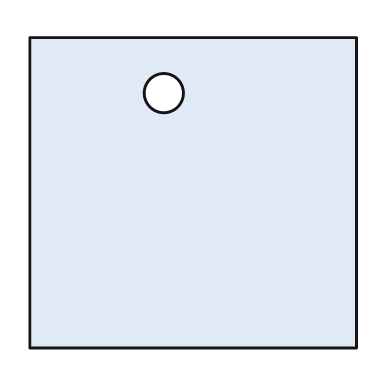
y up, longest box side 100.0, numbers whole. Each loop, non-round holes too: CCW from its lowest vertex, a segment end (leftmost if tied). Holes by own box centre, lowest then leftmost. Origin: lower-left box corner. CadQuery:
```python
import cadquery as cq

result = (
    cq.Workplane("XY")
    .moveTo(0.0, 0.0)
    .lineTo(100.0, 0.0)
    .lineTo(100.0, 95.0)
    .lineTo(0.0, 95.0)
    .close()
    .moveTo(41.0, 78.0)
    .circle(6.0)
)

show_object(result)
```